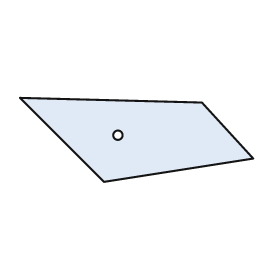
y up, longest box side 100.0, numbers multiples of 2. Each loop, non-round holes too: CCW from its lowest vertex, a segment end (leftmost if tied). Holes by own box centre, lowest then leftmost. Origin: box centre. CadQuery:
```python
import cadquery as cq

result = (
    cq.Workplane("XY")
    .moveTo(-14.0, -18.0)
    .lineTo(50.0, -8.0)
    .lineTo(28.0, 16.0)
    .lineTo(-50.0, 18.0)
    .close()
    .moveTo(-8.0, 2.0)
    .circle(2.0)
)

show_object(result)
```